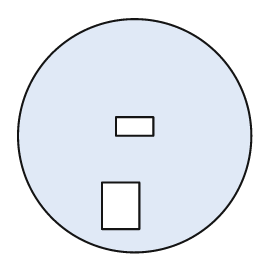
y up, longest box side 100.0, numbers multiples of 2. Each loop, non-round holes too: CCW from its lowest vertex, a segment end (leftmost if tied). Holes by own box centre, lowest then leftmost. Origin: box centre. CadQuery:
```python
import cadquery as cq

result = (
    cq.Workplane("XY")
    .moveTo(0.0, 0.0)
    .circle(50.0)
    .moveTo(-14.0, -40.0)
    .lineTo(2.0, -40.0)
    .lineTo(2.0, -20.0)
    .lineTo(-14.0, -20.0)
    .close()
    .moveTo(-8.0, 0.0)
    .lineTo(8.0, 0.0)
    .lineTo(8.0, 8.0)
    .lineTo(-8.0, 8.0)
    .close()
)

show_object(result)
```